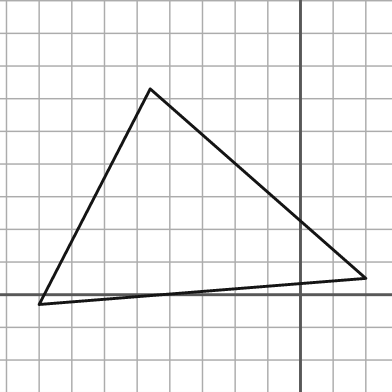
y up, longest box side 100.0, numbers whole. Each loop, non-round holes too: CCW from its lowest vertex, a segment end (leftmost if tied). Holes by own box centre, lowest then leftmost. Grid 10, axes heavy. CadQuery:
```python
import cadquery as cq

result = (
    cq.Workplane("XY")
    .moveTo(-80.0, -3.0)
    .lineTo(20.0, 5.0)
    .lineTo(-46.0, 63.0)
    .close()
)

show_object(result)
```